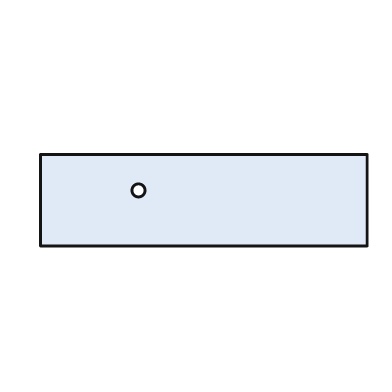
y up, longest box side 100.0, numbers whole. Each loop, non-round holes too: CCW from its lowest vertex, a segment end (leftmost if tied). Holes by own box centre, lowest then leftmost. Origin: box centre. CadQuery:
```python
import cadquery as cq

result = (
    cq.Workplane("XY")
    .moveTo(-50.0, -14.0)
    .lineTo(50.0, -14.0)
    .lineTo(50.0, 14.0)
    .lineTo(-50.0, 14.0)
    .close()
    .moveTo(-20.0, 3.0)
    .circle(2.0)
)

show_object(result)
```